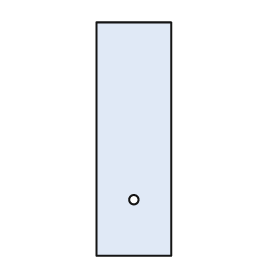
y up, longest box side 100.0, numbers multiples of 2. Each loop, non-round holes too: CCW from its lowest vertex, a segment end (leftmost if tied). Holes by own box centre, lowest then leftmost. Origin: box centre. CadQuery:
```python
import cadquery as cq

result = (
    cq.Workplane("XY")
    .moveTo(-16.0, -50.0)
    .lineTo(16.0, -50.0)
    .lineTo(16.0, 50.0)
    .lineTo(-16.0, 50.0)
    .close()
    .moveTo(0.0, -26.0)
    .circle(2.0)
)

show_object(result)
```